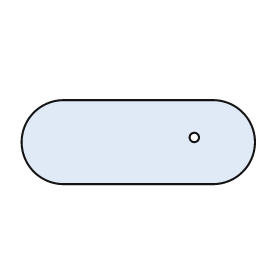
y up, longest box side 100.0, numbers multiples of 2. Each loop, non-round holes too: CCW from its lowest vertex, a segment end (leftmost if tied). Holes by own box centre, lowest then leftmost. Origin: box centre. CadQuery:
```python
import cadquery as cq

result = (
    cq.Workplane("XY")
    .moveTo(-32.0, -18.0)
    .lineTo(32.0, -18.0)
    .threePointArc((50.0, 0.0), (32.0, 18.0))
    .lineTo(-32.0, 18.0)
    .threePointArc((-50.0, 0.0), (-32.0, -18.0))
    .close()
    .moveTo(24.0, 2.0)
    .circle(2.0)
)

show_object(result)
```